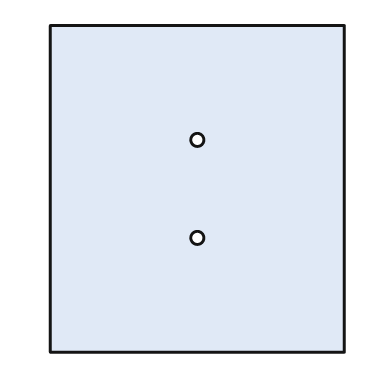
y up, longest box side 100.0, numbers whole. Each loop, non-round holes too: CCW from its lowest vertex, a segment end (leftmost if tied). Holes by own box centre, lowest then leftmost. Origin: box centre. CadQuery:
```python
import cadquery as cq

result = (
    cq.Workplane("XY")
    .moveTo(-45.0, -50.0)
    .lineTo(45.0, -50.0)
    .lineTo(45.0, 50.0)
    .lineTo(-45.0, 50.0)
    .close()
    .moveTo(0.0, -15.0)
    .circle(2.0)
    .moveTo(0.0, 15.0)
    .circle(2.0)
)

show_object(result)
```